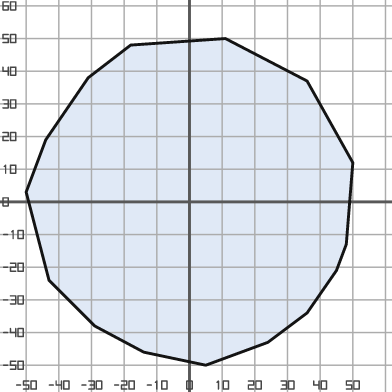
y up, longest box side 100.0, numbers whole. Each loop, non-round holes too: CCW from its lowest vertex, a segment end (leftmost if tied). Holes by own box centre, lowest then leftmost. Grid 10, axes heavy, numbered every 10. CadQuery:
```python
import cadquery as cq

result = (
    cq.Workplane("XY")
    .moveTo(5.0, -50.0)
    .lineTo(24.0, -43.0)
    .lineTo(36.0, -34.0)
    .lineTo(45.0, -21.0)
    .lineTo(48.0, -13.0)
    .lineTo(50.0, 12.0)
    .lineTo(36.0, 37.0)
    .lineTo(11.0, 50.0)
    .lineTo(-18.0, 48.0)
    .lineTo(-31.0, 38.0)
    .lineTo(-44.0, 19.0)
    .lineTo(-50.0, 3.0)
    .lineTo(-43.0, -24.0)
    .lineTo(-29.0, -38.0)
    .lineTo(-14.0, -46.0)
    .close()
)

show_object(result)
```